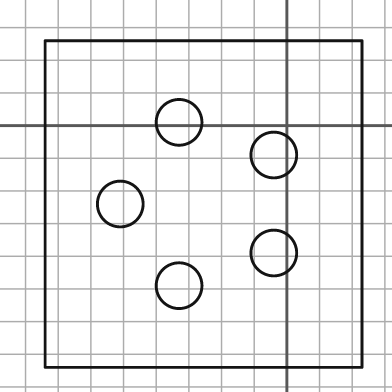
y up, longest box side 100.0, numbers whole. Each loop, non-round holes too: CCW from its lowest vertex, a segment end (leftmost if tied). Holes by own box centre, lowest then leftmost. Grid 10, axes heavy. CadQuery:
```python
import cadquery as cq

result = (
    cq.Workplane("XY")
    .moveTo(-74.0, -74.0)
    .lineTo(23.0, -74.0)
    .lineTo(23.0, 26.0)
    .lineTo(-74.0, 26.0)
    .close()
    .moveTo(-33.0, -49.0)
    .circle(7.0)
    .moveTo(-4.0, -39.0)
    .circle(7.0)
    .moveTo(-51.0, -24.0)
    .circle(7.0)
    .moveTo(-4.0, -9.0)
    .circle(7.0)
    .moveTo(-33.0, 1.0)
    .circle(7.0)
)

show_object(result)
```